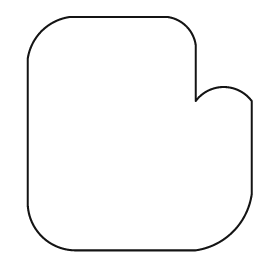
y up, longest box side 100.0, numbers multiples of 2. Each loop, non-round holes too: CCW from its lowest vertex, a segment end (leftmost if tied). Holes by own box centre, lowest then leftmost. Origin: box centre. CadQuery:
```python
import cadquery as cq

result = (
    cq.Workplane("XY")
    .moveTo(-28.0, -50.0)
    .lineTo(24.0, -50.0)
    .threePointArc((40.0, -42.0), (48.0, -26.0))
    .lineTo(48.0, 14.0)
    .threePointArc((36.0, 20.0), (24.0, 14.0))
    .lineTo(24.0, 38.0)
    .threePointArc((20.0, 46.0), (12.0, 50.0))
    .lineTo(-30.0, 50.0)
    .threePointArc((-42.0, 44.0), (-48.0, 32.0))
    .lineTo(-48.0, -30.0)
    .threePointArc((-42.0, -44.0), (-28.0, -50.0))
    .close()
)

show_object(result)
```